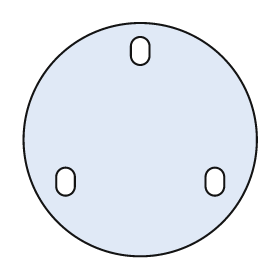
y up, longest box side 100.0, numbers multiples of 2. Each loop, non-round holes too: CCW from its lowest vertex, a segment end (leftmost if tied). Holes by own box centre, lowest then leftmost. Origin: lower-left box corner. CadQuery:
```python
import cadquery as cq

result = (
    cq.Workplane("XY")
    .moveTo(50.0, 50.0)
    .circle(50.0)
    .moveTo(14.0, 30.0)
    .threePointArc((18.0, 26.0), (22.0, 30.0))
    .lineTo(22.0, 34.0)
    .threePointArc((18.0, 38.0), (14.0, 34.0))
    .close()
    .moveTo(78.0, 30.0)
    .threePointArc((82.0, 26.0), (86.0, 30.0))
    .lineTo(86.0, 34.0)
    .threePointArc((82.0, 38.0), (78.0, 34.0))
    .close()
    .moveTo(46.0, 86.0)
    .threePointArc((50.0, 82.0), (54.0, 86.0))
    .lineTo(54.0, 90.0)
    .threePointArc((50.0, 94.0), (46.0, 90.0))
    .close()
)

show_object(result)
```